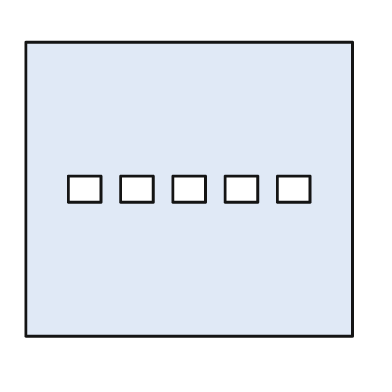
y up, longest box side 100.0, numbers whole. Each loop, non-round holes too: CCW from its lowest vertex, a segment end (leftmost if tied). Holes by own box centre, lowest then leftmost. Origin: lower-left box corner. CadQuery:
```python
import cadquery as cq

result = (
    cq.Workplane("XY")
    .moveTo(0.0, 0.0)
    .lineTo(100.0, 0.0)
    .lineTo(100.0, 90.0)
    .lineTo(0.0, 90.0)
    .close()
    .moveTo(13.0, 41.0)
    .lineTo(23.0, 41.0)
    .lineTo(23.0, 49.0)
    .lineTo(13.0, 49.0)
    .close()
    .moveTo(29.0, 41.0)
    .lineTo(39.0, 41.0)
    .lineTo(39.0, 49.0)
    .lineTo(29.0, 49.0)
    .close()
    .moveTo(45.0, 41.0)
    .lineTo(55.0, 41.0)
    .lineTo(55.0, 49.0)
    .lineTo(45.0, 49.0)
    .close()
    .moveTo(61.0, 41.0)
    .lineTo(71.0, 41.0)
    .lineTo(71.0, 49.0)
    .lineTo(61.0, 49.0)
    .close()
    .moveTo(77.0, 41.0)
    .lineTo(87.0, 41.0)
    .lineTo(87.0, 49.0)
    .lineTo(77.0, 49.0)
    .close()
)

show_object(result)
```